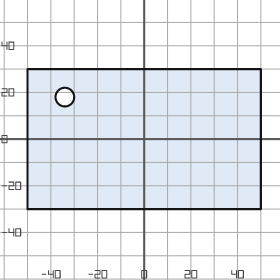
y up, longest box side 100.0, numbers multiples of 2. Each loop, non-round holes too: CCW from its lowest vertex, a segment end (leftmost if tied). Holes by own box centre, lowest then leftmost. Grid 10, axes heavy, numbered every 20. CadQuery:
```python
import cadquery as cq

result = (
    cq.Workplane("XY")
    .moveTo(-50.0, -30.0)
    .lineTo(50.0, -30.0)
    .lineTo(50.0, 30.0)
    .lineTo(-50.0, 30.0)
    .close()
    .moveTo(-34.0, 18.0)
    .circle(4.0)
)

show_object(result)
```